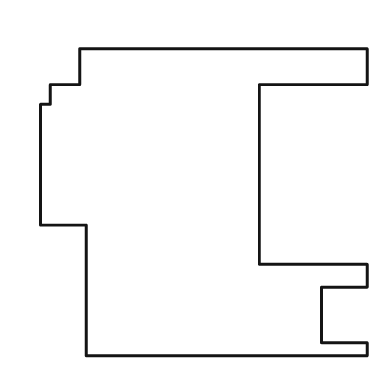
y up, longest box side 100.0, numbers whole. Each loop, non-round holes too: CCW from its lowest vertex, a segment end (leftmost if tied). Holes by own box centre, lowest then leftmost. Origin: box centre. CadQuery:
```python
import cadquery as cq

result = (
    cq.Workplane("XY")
    .moveTo(-36.0, -47.0)
    .lineTo(50.0, -47.0)
    .lineTo(50.0, -43.0)
    .lineTo(36.0, -43.0)
    .lineTo(36.0, -26.0)
    .lineTo(50.0, -26.0)
    .lineTo(50.0, -19.0)
    .lineTo(17.0, -19.0)
    .lineTo(17.0, 36.0)
    .lineTo(50.0, 36.0)
    .lineTo(50.0, 47.0)
    .lineTo(-38.0, 47.0)
    .lineTo(-38.0, 36.0)
    .lineTo(-47.0, 36.0)
    .lineTo(-47.0, 30.0)
    .lineTo(-50.0, 30.0)
    .lineTo(-50.0, -7.0)
    .lineTo(-36.0, -7.0)
    .close()
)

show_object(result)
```